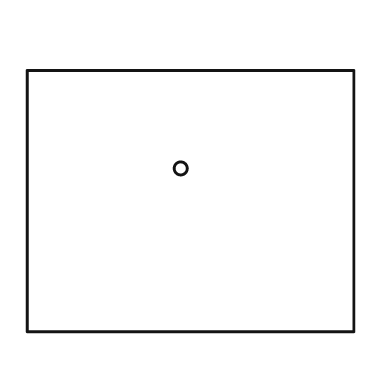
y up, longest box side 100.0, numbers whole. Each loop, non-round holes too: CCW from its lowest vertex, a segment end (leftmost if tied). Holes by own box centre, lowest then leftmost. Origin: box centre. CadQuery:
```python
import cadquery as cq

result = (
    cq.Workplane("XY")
    .moveTo(-50.0, -40.0)
    .lineTo(50.0, -40.0)
    .lineTo(50.0, 40.0)
    .lineTo(-50.0, 40.0)
    .close()
    .moveTo(-3.0, 10.0)
    .circle(2.0)
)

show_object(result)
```